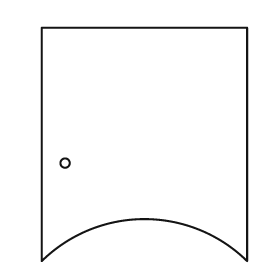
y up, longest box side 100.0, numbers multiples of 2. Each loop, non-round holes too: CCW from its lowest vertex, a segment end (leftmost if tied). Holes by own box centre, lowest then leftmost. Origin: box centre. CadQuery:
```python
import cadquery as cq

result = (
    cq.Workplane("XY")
    .moveTo(-44.0, -50.0)
    .threePointArc((0.0, -32.0), (44.0, -50.0))
    .lineTo(44.0, 50.0)
    .lineTo(-44.0, 50.0)
    .close()
    .moveTo(-34.0, -8.0)
    .circle(2.0)
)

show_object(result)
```